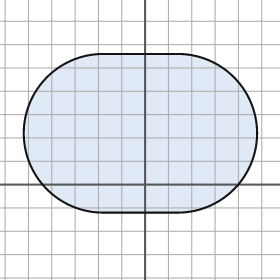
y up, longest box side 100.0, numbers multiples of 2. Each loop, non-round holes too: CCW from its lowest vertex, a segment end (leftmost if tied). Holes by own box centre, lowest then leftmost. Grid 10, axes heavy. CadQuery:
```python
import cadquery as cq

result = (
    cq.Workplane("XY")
    .moveTo(-18.0, -12.0)
    .lineTo(14.0, -12.0)
    .threePointArc((48.0, 22.0), (14.0, 56.0))
    .lineTo(-18.0, 56.0)
    .threePointArc((-52.0, 22.0), (-18.0, -12.0))
    .close()
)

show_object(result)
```